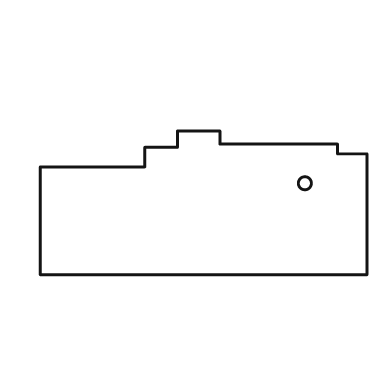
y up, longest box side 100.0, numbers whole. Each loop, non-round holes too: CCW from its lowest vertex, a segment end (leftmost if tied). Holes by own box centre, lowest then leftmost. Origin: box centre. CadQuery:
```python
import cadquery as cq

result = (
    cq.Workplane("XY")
    .moveTo(-50.0, -22.0)
    .lineTo(50.0, -22.0)
    .lineTo(50.0, 15.0)
    .lineTo(41.0, 15.0)
    .lineTo(41.0, 18.0)
    .lineTo(5.0, 18.0)
    .lineTo(5.0, 22.0)
    .lineTo(-8.0, 22.0)
    .lineTo(-8.0, 17.0)
    .lineTo(-18.0, 17.0)
    .lineTo(-18.0, 11.0)
    .lineTo(-50.0, 11.0)
    .close()
    .moveTo(31.0, 6.0)
    .circle(2.0)
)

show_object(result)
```